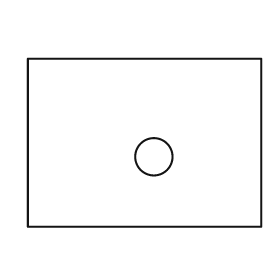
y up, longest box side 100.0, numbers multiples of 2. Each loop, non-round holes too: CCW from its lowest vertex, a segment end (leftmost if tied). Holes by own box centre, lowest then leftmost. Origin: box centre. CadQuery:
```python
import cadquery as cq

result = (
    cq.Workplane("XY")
    .moveTo(-50.0, -36.0)
    .lineTo(50.0, -36.0)
    .lineTo(50.0, 36.0)
    .lineTo(-50.0, 36.0)
    .close()
    .moveTo(4.0, -6.0)
    .circle(8.0)
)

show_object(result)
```